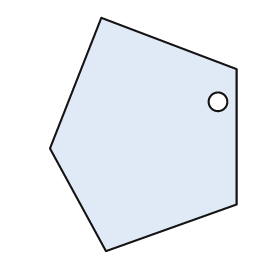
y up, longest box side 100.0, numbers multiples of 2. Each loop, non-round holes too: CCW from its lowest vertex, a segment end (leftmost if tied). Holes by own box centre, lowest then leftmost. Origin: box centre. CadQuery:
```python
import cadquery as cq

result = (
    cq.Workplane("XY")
    .moveTo(-16.0, -50.0)
    .lineTo(40.0, -30.0)
    .lineTo(40.0, 28.0)
    .lineTo(-18.0, 50.0)
    .lineTo(-40.0, -6.0)
    .close()
    .moveTo(32.0, 14.0)
    .circle(4.0)
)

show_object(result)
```